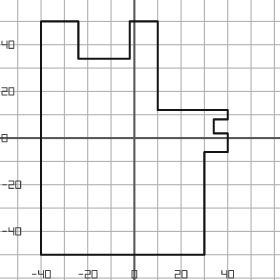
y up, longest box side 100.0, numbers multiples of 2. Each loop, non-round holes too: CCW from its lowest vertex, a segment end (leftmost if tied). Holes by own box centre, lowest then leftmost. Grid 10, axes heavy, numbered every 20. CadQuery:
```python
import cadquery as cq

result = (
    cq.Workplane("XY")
    .moveTo(-40.0, -50.0)
    .lineTo(30.0, -50.0)
    .lineTo(30.0, -6.0)
    .lineTo(40.0, -6.0)
    .lineTo(40.0, 2.0)
    .lineTo(34.0, 2.0)
    .lineTo(34.0, 8.0)
    .lineTo(40.0, 8.0)
    .lineTo(40.0, 12.0)
    .lineTo(10.0, 12.0)
    .lineTo(10.0, 50.0)
    .lineTo(-2.0, 50.0)
    .lineTo(-2.0, 34.0)
    .lineTo(-24.0, 34.0)
    .lineTo(-24.0, 50.0)
    .lineTo(-40.0, 50.0)
    .close()
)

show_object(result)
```